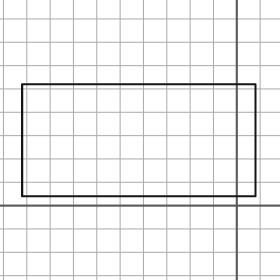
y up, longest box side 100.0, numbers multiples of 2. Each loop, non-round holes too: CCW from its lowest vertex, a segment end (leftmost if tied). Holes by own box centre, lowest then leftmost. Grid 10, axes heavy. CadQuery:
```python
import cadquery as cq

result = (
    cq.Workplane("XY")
    .moveTo(-92.0, 4.0)
    .lineTo(8.0, 4.0)
    .lineTo(8.0, 52.0)
    .lineTo(-92.0, 52.0)
    .close()
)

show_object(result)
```